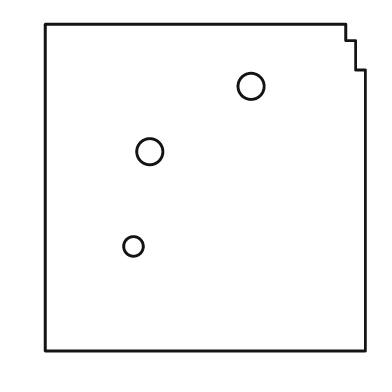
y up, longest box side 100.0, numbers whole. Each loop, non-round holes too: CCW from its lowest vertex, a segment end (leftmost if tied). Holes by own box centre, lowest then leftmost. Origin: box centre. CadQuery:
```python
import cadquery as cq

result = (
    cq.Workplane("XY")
    .moveTo(-49.0, -50.0)
    .lineTo(49.0, -50.0)
    .lineTo(49.0, 36.0)
    .lineTo(46.0, 36.0)
    .lineTo(46.0, 45.0)
    .lineTo(43.0, 45.0)
    .lineTo(43.0, 50.0)
    .lineTo(-49.0, 50.0)
    .close()
    .moveTo(-22.0, -18.0)
    .circle(3.0)
    .moveTo(-17.0, 11.0)
    .circle(4.0)
    .moveTo(14.0, 31.0)
    .circle(4.0)
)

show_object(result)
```